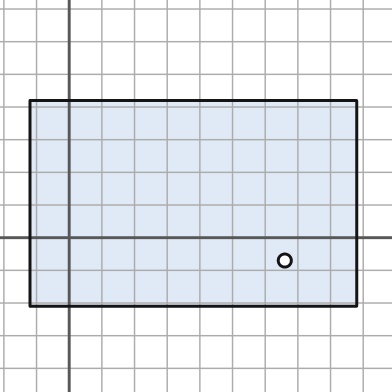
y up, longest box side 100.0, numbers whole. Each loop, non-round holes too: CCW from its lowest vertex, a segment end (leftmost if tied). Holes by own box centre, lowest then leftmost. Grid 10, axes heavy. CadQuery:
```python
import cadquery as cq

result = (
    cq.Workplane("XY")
    .moveTo(-12.0, -21.0)
    .lineTo(88.0, -21.0)
    .lineTo(88.0, 42.0)
    .lineTo(-12.0, 42.0)
    .close()
    .moveTo(66.0, -7.0)
    .circle(2.0)
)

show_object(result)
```